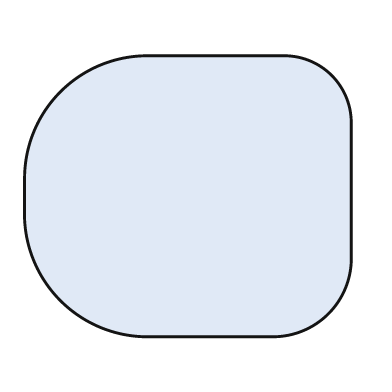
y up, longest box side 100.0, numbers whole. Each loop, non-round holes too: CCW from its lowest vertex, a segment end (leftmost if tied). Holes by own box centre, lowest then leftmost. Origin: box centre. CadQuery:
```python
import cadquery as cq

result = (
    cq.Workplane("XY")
    .moveTo(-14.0, -43.0)
    .lineTo(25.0, -43.0)
    .threePointArc((43.0, -36.0), (50.0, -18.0))
    .lineTo(50.0, 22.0)
    .threePointArc((44.0, 37.0), (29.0, 43.0))
    .lineTo(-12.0, 43.0)
    .threePointArc((-39.0, 32.0), (-50.0, 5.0))
    .lineTo(-50.0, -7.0)
    .threePointArc((-39.0, -32.0), (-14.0, -43.0))
    .close()
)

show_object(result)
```